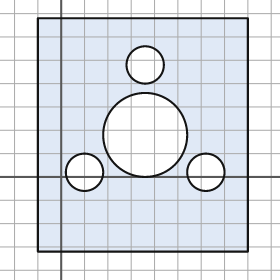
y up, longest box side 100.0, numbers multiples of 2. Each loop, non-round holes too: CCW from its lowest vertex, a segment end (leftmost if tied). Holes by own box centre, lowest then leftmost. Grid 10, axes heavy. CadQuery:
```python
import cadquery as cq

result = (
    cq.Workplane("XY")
    .moveTo(-10.0, -32.0)
    .lineTo(80.0, -32.0)
    .lineTo(80.0, 68.0)
    .lineTo(-10.0, 68.0)
    .close()
    .moveTo(10.0, 2.0)
    .circle(8.0)
    .moveTo(62.0, 2.0)
    .circle(8.0)
    .moveTo(36.0, 18.0)
    .circle(18.0)
    .moveTo(36.0, 48.0)
    .circle(8.0)
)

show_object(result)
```